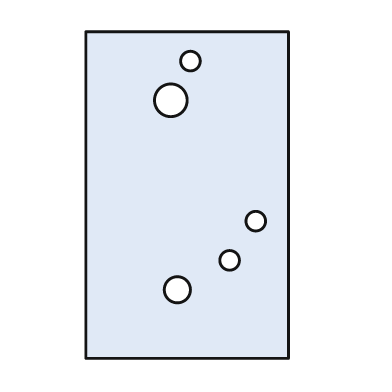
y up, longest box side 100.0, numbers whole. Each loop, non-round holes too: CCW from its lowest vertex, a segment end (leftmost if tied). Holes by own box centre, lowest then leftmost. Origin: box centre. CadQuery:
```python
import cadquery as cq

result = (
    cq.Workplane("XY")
    .moveTo(-31.0, -50.0)
    .lineTo(31.0, -50.0)
    .lineTo(31.0, 50.0)
    .lineTo(-31.0, 50.0)
    .close()
    .moveTo(-3.0, -29.0)
    .circle(4.0)
    .moveTo(13.0, -20.0)
    .circle(3.0)
    .moveTo(21.0, -8.0)
    .circle(3.0)
    .moveTo(-5.0, 29.0)
    .circle(5.0)
    .moveTo(1.0, 41.0)
    .circle(3.0)
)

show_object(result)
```